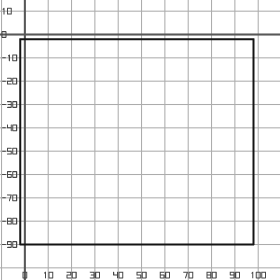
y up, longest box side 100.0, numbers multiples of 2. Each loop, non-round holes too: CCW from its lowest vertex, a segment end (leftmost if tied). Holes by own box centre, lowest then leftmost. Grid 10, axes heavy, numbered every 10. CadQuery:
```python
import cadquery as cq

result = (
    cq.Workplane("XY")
    .moveTo(-2.0, -90.0)
    .lineTo(98.0, -90.0)
    .lineTo(98.0, -2.0)
    .lineTo(-2.0, -2.0)
    .close()
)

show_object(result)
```